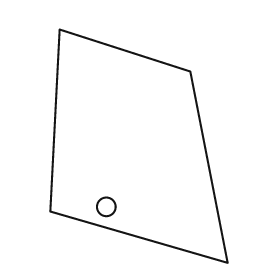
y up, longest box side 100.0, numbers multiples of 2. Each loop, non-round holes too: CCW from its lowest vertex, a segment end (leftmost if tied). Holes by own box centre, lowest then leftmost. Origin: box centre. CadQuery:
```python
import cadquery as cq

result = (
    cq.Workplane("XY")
    .moveTo(38.0, -50.0)
    .lineTo(22.0, 32.0)
    .lineTo(-34.0, 50.0)
    .lineTo(-38.0, -28.0)
    .close()
    .moveTo(-14.0, -26.0)
    .circle(4.0)
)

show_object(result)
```